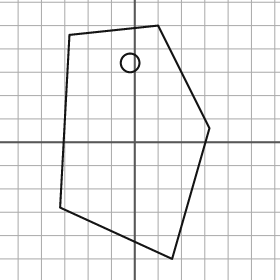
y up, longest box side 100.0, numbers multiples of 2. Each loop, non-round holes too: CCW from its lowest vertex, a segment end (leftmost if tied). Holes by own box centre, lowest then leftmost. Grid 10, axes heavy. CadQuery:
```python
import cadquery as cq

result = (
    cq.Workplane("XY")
    .moveTo(16.0, -50.0)
    .lineTo(32.0, 6.0)
    .lineTo(10.0, 50.0)
    .lineTo(-28.0, 46.0)
    .lineTo(-32.0, -28.0)
    .close()
    .moveTo(-2.0, 34.0)
    .circle(4.0)
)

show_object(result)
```